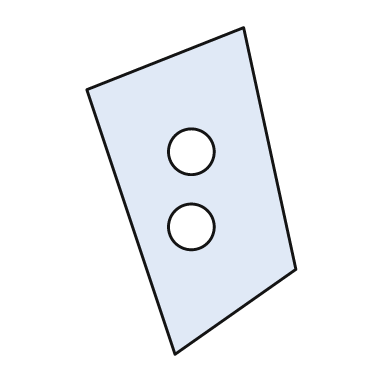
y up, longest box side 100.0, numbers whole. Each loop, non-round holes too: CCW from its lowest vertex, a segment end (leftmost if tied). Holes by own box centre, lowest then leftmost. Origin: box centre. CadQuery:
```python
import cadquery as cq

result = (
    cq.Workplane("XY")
    .moveTo(-5.0, -50.0)
    .lineTo(32.0, -24.0)
    .lineTo(16.0, 50.0)
    .lineTo(-32.0, 31.0)
    .close()
    .moveTo(0.0, -11.0)
    .circle(7.0)
    .moveTo(0.0, 12.0)
    .circle(7.0)
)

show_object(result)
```